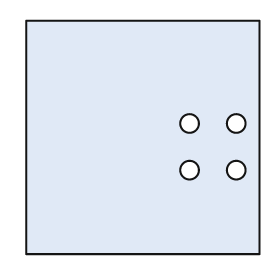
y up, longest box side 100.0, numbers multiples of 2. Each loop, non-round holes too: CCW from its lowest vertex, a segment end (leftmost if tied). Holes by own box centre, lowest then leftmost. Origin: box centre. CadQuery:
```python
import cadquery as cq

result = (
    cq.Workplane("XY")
    .moveTo(-50.0, -50.0)
    .lineTo(50.0, -50.0)
    .lineTo(50.0, 50.0)
    .lineTo(-50.0, 50.0)
    .close()
    .moveTo(20.0, -14.0)
    .circle(4.0)
    .moveTo(40.0, -14.0)
    .circle(4.0)
    .moveTo(20.0, 6.0)
    .circle(4.0)
    .moveTo(40.0, 6.0)
    .circle(4.0)
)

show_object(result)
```